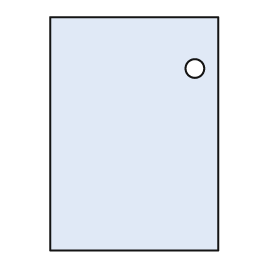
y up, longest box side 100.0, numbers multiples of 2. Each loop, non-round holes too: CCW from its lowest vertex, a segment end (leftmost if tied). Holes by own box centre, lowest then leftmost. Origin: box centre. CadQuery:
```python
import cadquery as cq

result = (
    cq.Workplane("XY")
    .moveTo(-36.0, -50.0)
    .lineTo(36.0, -50.0)
    .lineTo(36.0, 50.0)
    .lineTo(-36.0, 50.0)
    .close()
    .moveTo(26.0, 28.0)
    .circle(4.0)
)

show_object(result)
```